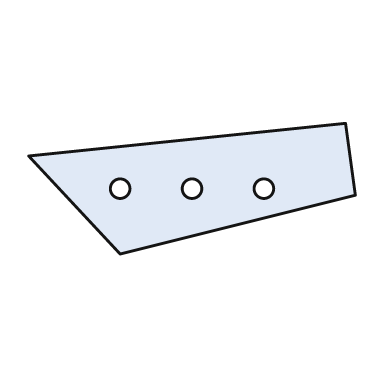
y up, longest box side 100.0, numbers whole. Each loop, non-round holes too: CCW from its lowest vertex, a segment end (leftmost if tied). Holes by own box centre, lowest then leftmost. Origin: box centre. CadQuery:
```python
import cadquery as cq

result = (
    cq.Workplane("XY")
    .moveTo(-22.0, -20.0)
    .lineTo(50.0, -2.0)
    .lineTo(47.0, 20.0)
    .lineTo(-50.0, 10.0)
    .close()
    .moveTo(-22.0, 0.0)
    .circle(3.0)
    .moveTo(0.0, 0.0)
    .circle(3.0)
    .moveTo(22.0, 0.0)
    .circle(3.0)
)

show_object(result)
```